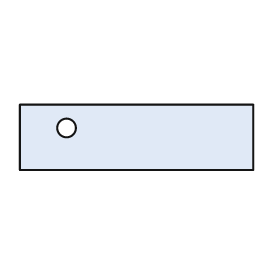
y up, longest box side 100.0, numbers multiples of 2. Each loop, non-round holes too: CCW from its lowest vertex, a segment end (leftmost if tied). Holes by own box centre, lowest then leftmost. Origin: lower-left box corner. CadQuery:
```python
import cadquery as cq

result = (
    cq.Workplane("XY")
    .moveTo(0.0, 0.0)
    .lineTo(100.0, 0.0)
    .lineTo(100.0, 28.0)
    .lineTo(0.0, 28.0)
    .close()
    .moveTo(20.0, 18.0)
    .circle(4.0)
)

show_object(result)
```